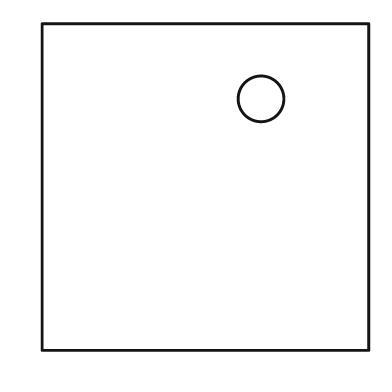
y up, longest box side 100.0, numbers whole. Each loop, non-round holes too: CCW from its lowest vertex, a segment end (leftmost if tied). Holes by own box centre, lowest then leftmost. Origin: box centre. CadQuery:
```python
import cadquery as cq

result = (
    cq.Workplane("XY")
    .moveTo(-50.0, -50.0)
    .lineTo(50.0, -50.0)
    .lineTo(50.0, 50.0)
    .lineTo(-50.0, 50.0)
    .close()
    .moveTo(17.0, 27.0)
    .circle(7.0)
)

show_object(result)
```